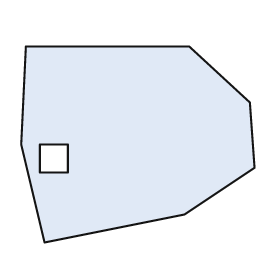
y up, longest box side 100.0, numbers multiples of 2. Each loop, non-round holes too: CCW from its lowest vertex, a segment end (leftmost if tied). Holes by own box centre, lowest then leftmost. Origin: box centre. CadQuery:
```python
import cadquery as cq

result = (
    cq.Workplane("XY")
    .moveTo(-40.0, -42.0)
    .lineTo(20.0, -30.0)
    .lineTo(50.0, -10.0)
    .lineTo(48.0, 18.0)
    .lineTo(22.0, 42.0)
    .lineTo(-48.0, 42.0)
    .lineTo(-50.0, 0.0)
    .close()
    .moveTo(-42.0, -12.0)
    .lineTo(-30.0, -12.0)
    .lineTo(-30.0, 0.0)
    .lineTo(-42.0, 0.0)
    .close()
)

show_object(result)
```